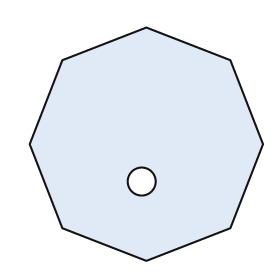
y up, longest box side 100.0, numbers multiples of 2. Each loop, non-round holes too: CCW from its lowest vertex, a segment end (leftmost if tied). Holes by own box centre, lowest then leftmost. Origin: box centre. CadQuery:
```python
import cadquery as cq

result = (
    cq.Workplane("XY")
    .moveTo(0.0, -50.0)
    .lineTo(36.0, -36.0)
    .lineTo(50.0, 0.0)
    .lineTo(36.0, 36.0)
    .lineTo(0.0, 50.0)
    .lineTo(-36.0, 36.0)
    .lineTo(-50.0, 0.0)
    .lineTo(-36.0, -36.0)
    .close()
    .moveTo(-2.0, -16.0)
    .circle(6.0)
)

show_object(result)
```